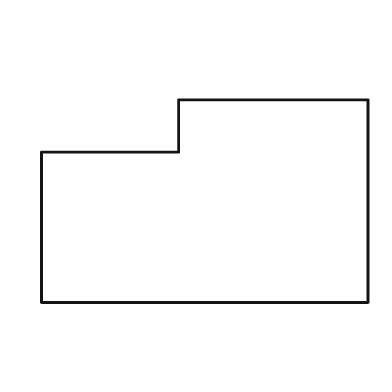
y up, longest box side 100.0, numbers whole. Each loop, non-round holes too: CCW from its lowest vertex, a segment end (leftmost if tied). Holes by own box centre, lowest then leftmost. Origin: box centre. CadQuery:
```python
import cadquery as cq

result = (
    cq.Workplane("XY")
    .moveTo(-50.0, -31.0)
    .lineTo(50.0, -31.0)
    .lineTo(50.0, 31.0)
    .lineTo(-8.0, 31.0)
    .lineTo(-8.0, 15.0)
    .lineTo(-50.0, 15.0)
    .close()
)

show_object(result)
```